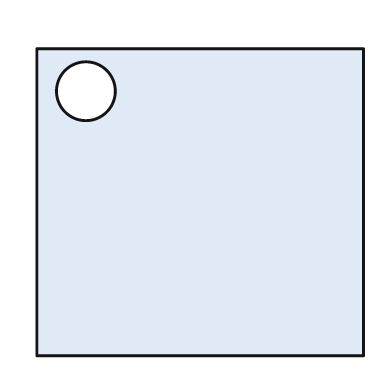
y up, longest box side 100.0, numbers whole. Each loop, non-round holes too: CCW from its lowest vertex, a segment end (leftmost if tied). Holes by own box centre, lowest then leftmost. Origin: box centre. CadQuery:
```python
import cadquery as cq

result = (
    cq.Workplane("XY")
    .moveTo(-50.0, -47.0)
    .lineTo(50.0, -47.0)
    .lineTo(50.0, 47.0)
    .lineTo(-50.0, 47.0)
    .close()
    .moveTo(-35.0, 34.0)
    .circle(9.0)
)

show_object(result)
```